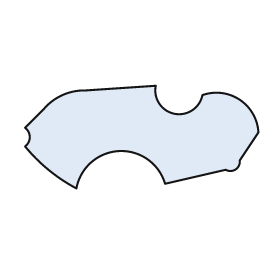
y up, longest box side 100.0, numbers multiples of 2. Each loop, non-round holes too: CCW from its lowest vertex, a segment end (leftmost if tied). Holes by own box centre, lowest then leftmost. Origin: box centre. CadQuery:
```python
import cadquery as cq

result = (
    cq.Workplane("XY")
    .moveTo(-28.0, -22.0)
    .threePointArc((-10.0, -6.0), (10.0, -20.0))
    .lineTo(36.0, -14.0)
    .threePointArc((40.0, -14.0), (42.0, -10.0))
    .lineTo(50.0, 2.0)
    .threePointArc((42.0, 16.0), (26.0, 18.0))
    .threePointArc((14.0, 10.0), (6.0, 22.0))
    .lineTo(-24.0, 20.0)
    .threePointArc((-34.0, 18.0), (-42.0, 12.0))
    .lineTo(-50.0, 4.0)
    .threePointArc((-48.0, 0.0), (-50.0, -4.0))
    .threePointArc((-40.0, -14.0), (-28.0, -22.0))
    .close()
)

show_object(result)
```